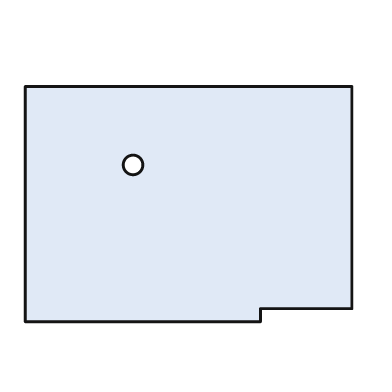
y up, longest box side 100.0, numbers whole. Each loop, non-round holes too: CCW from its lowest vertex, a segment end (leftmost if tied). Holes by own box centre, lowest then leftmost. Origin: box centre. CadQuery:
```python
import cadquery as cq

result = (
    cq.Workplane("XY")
    .moveTo(-50.0, -36.0)
    .lineTo(22.0, -36.0)
    .lineTo(22.0, -32.0)
    .lineTo(50.0, -32.0)
    .lineTo(50.0, 36.0)
    .lineTo(-50.0, 36.0)
    .close()
    .moveTo(-17.0, 12.0)
    .circle(3.0)
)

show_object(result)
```